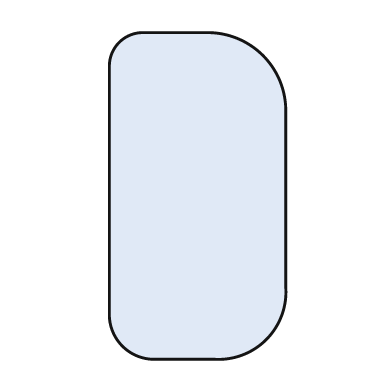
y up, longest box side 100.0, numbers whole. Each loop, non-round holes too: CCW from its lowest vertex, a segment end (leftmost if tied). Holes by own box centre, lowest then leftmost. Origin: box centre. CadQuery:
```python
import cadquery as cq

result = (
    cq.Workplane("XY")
    .moveTo(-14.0, -50.0)
    .lineTo(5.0, -50.0)
    .threePointArc((21.0, -44.0), (27.0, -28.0))
    .lineTo(27.0, 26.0)
    .threePointArc((20.0, 43.0), (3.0, 50.0))
    .lineTo(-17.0, 50.0)
    .threePointArc((-24.0, 47.0), (-27.0, 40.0))
    .lineTo(-27.0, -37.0)
    .threePointArc((-23.0, -46.0), (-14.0, -50.0))
    .close()
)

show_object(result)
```